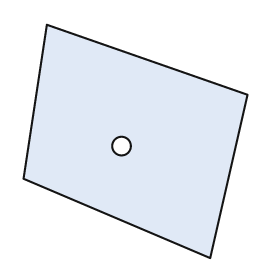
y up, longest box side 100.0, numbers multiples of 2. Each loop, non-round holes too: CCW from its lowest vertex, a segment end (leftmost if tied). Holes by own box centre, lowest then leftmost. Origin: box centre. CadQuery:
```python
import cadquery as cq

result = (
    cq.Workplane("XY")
    .moveTo(32.0, -50.0)
    .lineTo(48.0, 20.0)
    .lineTo(-38.0, 50.0)
    .lineTo(-48.0, -16.0)
    .close()
    .moveTo(-6.0, -2.0)
    .circle(4.0)
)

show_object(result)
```